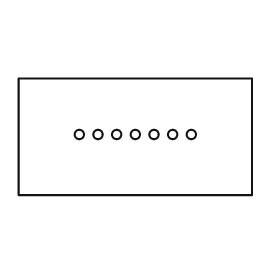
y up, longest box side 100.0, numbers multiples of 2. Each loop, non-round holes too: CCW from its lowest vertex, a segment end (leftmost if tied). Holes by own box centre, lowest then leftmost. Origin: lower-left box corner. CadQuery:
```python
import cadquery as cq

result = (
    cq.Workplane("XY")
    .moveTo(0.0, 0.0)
    .lineTo(100.0, 0.0)
    .lineTo(100.0, 50.0)
    .lineTo(0.0, 50.0)
    .close()
    .moveTo(26.0, 26.0)
    .circle(2.0)
    .moveTo(34.0, 26.0)
    .circle(2.0)
    .moveTo(42.0, 26.0)
    .circle(2.0)
    .moveTo(50.0, 26.0)
    .circle(2.0)
    .moveTo(58.0, 26.0)
    .circle(2.0)
    .moveTo(66.0, 26.0)
    .circle(2.0)
    .moveTo(74.0, 26.0)
    .circle(2.0)
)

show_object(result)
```